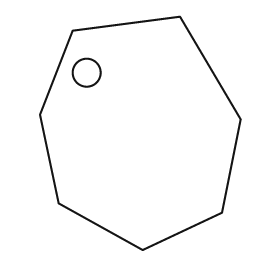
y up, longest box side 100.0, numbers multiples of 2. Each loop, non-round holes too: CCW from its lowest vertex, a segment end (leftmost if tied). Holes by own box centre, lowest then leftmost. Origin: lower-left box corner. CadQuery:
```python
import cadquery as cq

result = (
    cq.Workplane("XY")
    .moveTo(44.0, 0.0)
    .lineTo(78.0, 16.0)
    .lineTo(86.0, 56.0)
    .lineTo(60.0, 100.0)
    .lineTo(14.0, 94.0)
    .lineTo(0.0, 58.0)
    .lineTo(8.0, 20.0)
    .close()
    .moveTo(20.0, 76.0)
    .circle(6.0)
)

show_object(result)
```